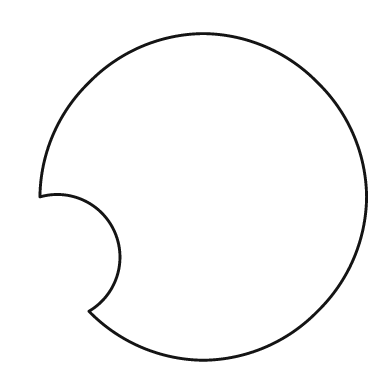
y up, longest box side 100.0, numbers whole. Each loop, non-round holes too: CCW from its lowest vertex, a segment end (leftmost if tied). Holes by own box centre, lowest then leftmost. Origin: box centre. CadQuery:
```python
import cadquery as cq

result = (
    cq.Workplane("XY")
    .moveTo(0.0, -50.0)
    .threePointArc((19.0, -46.0), (35.0, -35.0))
    .threePointArc((46.0, -19.0), (50.0, 0.0))
    .threePointArc((46.0, 19.0), (35.0, 35.0))
    .threePointArc((19.0, 46.0), (0.0, 50.0))
    .threePointArc((-19.0, 46.0), (-35.0, 35.0))
    .threePointArc((-46.0, 19.0), (-50.0, 0.0))
    .threePointArc((-27.0, -11.0), (-35.0, -35.0))
    .threePointArc((-19.0, -46.0), (0.0, -50.0))
    .close()
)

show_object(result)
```